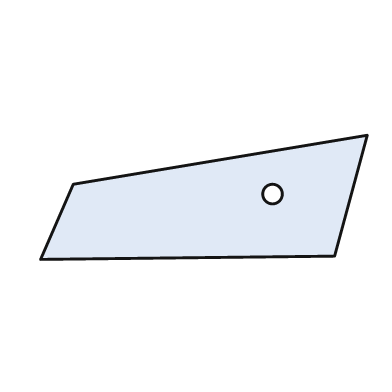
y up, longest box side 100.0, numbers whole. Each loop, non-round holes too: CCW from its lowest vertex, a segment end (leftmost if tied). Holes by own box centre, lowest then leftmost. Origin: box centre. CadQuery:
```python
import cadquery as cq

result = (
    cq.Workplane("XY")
    .moveTo(-50.0, -19.0)
    .lineTo(40.0, -18.0)
    .lineTo(50.0, 19.0)
    .lineTo(-40.0, 4.0)
    .close()
    .moveTo(21.0, 1.0)
    .circle(3.0)
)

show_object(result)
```